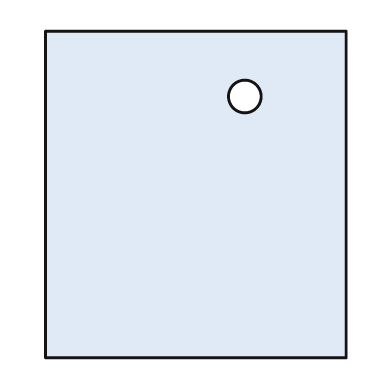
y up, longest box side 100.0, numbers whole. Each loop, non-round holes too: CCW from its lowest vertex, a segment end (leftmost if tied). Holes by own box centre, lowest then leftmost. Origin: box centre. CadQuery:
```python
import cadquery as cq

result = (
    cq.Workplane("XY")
    .moveTo(-46.0, -50.0)
    .lineTo(46.0, -50.0)
    .lineTo(46.0, 50.0)
    .lineTo(-46.0, 50.0)
    .close()
    .moveTo(15.0, 30.0)
    .circle(5.0)
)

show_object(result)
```